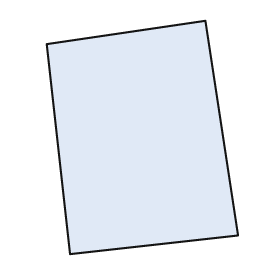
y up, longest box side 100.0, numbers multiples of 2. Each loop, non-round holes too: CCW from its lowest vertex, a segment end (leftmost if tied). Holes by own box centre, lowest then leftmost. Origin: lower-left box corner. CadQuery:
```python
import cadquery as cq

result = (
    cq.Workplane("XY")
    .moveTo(10.0, 0.0)
    .lineTo(82.0, 8.0)
    .lineTo(68.0, 100.0)
    .lineTo(0.0, 90.0)
    .close()
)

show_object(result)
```